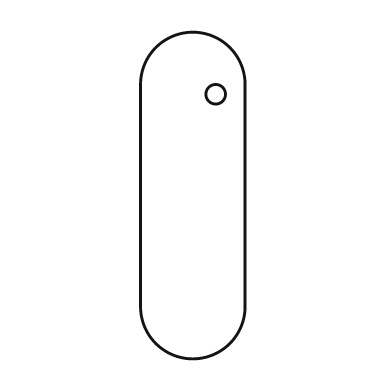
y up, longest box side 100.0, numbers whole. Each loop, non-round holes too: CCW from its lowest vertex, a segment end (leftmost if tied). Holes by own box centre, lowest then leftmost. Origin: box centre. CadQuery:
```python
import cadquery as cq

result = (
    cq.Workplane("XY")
    .moveTo(-16.0, -34.0)
    .threePointArc((0.0, -50.0), (16.0, -34.0))
    .lineTo(16.0, 34.0)
    .threePointArc((0.0, 50.0), (-16.0, 34.0))
    .close()
    .moveTo(7.0, 31.0)
    .circle(3.0)
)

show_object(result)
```